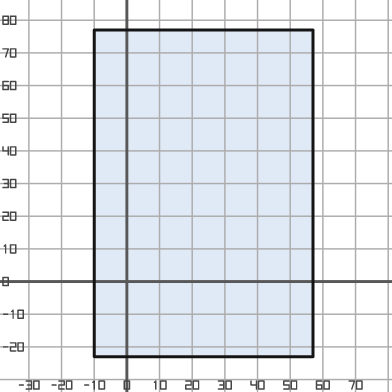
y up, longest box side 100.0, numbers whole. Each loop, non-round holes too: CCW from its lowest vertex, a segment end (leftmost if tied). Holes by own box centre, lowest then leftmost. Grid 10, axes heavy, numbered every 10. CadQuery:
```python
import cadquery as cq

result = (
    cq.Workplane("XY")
    .moveTo(-10.0, -23.0)
    .lineTo(57.0, -23.0)
    .lineTo(57.0, 77.0)
    .lineTo(-10.0, 77.0)
    .close()
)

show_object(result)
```